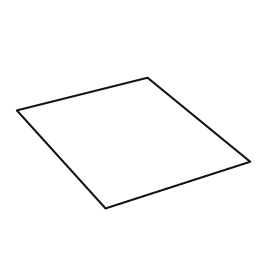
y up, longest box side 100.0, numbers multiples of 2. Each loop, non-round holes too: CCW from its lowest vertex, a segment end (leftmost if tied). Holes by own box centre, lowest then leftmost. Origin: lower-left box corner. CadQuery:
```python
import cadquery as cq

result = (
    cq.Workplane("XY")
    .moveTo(38.0, 0.0)
    .lineTo(100.0, 20.0)
    .lineTo(56.0, 56.0)
    .lineTo(0.0, 42.0)
    .close()
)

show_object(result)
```